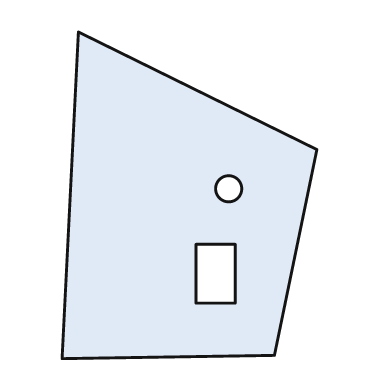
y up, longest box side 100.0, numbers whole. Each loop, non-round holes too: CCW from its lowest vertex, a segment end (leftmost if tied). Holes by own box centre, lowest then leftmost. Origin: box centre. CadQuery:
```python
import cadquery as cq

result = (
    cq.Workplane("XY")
    .moveTo(-39.0, -50.0)
    .lineTo(26.0, -49.0)
    .lineTo(39.0, 14.0)
    .lineTo(-34.0, 50.0)
    .close()
    .moveTo(2.0, -33.0)
    .lineTo(14.0, -33.0)
    .lineTo(14.0, -15.0)
    .lineTo(2.0, -15.0)
    .close()
    .moveTo(12.0, 2.0)
    .circle(4.0)
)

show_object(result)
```